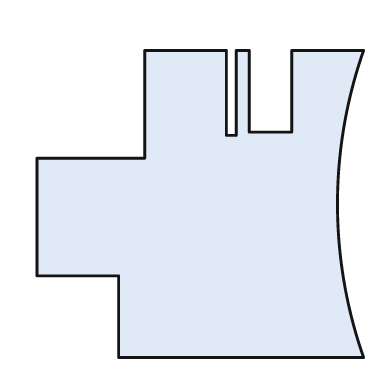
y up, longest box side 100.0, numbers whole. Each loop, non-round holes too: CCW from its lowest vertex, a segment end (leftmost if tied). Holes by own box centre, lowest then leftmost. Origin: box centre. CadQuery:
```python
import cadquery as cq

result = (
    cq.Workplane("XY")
    .moveTo(-25.0, -47.0)
    .lineTo(50.0, -47.0)
    .threePointArc((42.0, 0.0), (50.0, 47.0))
    .lineTo(28.0, 47.0)
    .lineTo(28.0, 22.0)
    .lineTo(15.0, 22.0)
    .lineTo(15.0, 47.0)
    .lineTo(11.0, 47.0)
    .lineTo(11.0, 21.0)
    .lineTo(8.0, 21.0)
    .lineTo(8.0, 47.0)
    .lineTo(-17.0, 47.0)
    .lineTo(-17.0, 14.0)
    .lineTo(-50.0, 14.0)
    .lineTo(-50.0, -22.0)
    .lineTo(-25.0, -22.0)
    .close()
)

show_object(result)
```